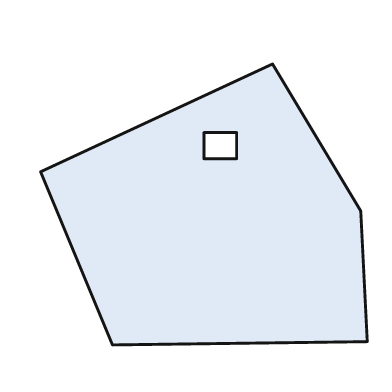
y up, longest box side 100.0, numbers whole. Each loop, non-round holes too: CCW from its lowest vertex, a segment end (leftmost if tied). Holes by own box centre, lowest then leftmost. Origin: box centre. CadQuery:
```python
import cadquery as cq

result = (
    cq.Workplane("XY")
    .moveTo(-28.0, -43.0)
    .lineTo(50.0, -42.0)
    .lineTo(48.0, -2.0)
    .lineTo(21.0, 43.0)
    .lineTo(-50.0, 10.0)
    .close()
    .moveTo(0.0, 14.0)
    .lineTo(10.0, 14.0)
    .lineTo(10.0, 22.0)
    .lineTo(0.0, 22.0)
    .close()
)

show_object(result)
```